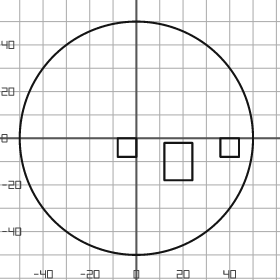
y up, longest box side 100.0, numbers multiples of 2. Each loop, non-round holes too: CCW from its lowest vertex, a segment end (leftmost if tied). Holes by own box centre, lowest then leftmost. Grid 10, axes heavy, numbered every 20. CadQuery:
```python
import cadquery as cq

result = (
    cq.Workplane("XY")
    .moveTo(0.0, 0.0)
    .circle(50.0)
    .moveTo(12.0, -18.0)
    .lineTo(24.0, -18.0)
    .lineTo(24.0, -2.0)
    .lineTo(12.0, -2.0)
    .close()
    .moveTo(-8.0, -8.0)
    .lineTo(0.0, -8.0)
    .lineTo(0.0, 0.0)
    .lineTo(-8.0, 0.0)
    .close()
    .moveTo(36.0, -8.0)
    .lineTo(44.0, -8.0)
    .lineTo(44.0, 0.0)
    .lineTo(36.0, 0.0)
    .close()
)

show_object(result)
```